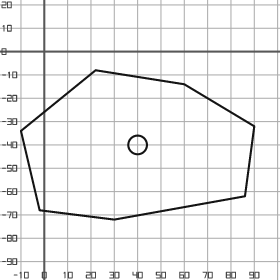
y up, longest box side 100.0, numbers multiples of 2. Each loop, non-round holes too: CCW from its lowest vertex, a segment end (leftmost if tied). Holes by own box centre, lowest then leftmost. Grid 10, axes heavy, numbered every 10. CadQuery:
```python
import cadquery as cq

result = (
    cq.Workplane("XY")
    .moveTo(30.0, -72.0)
    .lineTo(86.0, -62.0)
    .lineTo(90.0, -32.0)
    .lineTo(60.0, -14.0)
    .lineTo(22.0, -8.0)
    .lineTo(-10.0, -34.0)
    .lineTo(-2.0, -68.0)
    .close()
    .moveTo(40.0, -40.0)
    .circle(4.0)
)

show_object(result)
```